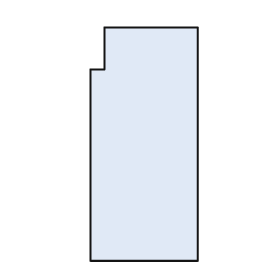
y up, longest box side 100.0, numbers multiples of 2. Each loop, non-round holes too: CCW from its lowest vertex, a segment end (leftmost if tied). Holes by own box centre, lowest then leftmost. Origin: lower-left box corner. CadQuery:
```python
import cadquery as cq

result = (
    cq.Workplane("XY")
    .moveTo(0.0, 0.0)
    .lineTo(46.0, 0.0)
    .lineTo(46.0, 100.0)
    .lineTo(6.0, 100.0)
    .lineTo(6.0, 82.0)
    .lineTo(0.0, 82.0)
    .close()
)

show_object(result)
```